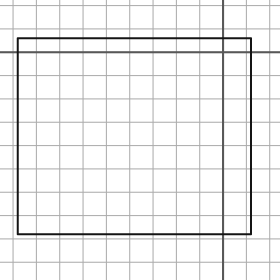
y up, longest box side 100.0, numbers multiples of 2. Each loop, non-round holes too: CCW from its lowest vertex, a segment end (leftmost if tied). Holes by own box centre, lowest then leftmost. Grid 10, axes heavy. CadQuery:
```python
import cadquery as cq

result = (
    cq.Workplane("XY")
    .moveTo(-88.0, -78.0)
    .lineTo(12.0, -78.0)
    .lineTo(12.0, 6.0)
    .lineTo(-88.0, 6.0)
    .close()
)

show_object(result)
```